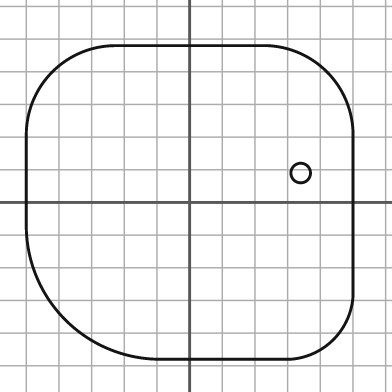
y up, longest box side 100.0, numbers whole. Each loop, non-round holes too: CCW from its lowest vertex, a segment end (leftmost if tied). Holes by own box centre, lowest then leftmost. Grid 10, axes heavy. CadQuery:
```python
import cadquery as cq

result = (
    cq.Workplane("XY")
    .moveTo(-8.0, -48.0)
    .lineTo(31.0, -48.0)
    .threePointArc((44.0, -42.0), (50.0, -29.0))
    .lineTo(50.0, 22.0)
    .threePointArc((42.0, 40.0), (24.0, 48.0))
    .lineTo(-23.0, 48.0)
    .threePointArc((-42.0, 40.0), (-50.0, 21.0))
    .lineTo(-50.0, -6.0)
    .threePointArc((-38.0, -36.0), (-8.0, -48.0))
    .close()
    .moveTo(34.0, 9.0)
    .circle(3.0)
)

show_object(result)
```